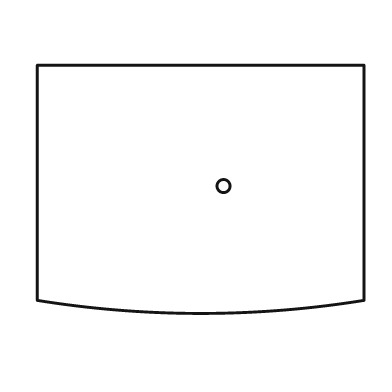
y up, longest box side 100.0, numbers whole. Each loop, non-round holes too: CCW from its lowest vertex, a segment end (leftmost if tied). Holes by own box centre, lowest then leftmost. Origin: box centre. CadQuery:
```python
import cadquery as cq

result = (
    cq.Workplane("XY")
    .moveTo(-50.0, -34.0)
    .threePointArc((0.0, -38.0), (50.0, -34.0))
    .lineTo(50.0, 38.0)
    .lineTo(-50.0, 38.0)
    .close()
    .moveTo(7.0, 1.0)
    .circle(2.0)
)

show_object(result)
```